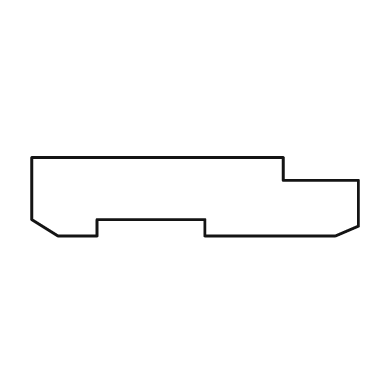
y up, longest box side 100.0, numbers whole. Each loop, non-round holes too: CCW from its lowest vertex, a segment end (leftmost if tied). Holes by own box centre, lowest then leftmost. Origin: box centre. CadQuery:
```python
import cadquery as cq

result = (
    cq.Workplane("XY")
    .moveTo(-42.0, -12.0)
    .lineTo(-30.0, -12.0)
    .lineTo(-30.0, -7.0)
    .lineTo(3.0, -7.0)
    .lineTo(3.0, -12.0)
    .lineTo(43.0, -12.0)
    .lineTo(50.0, -9.0)
    .lineTo(50.0, 5.0)
    .lineTo(27.0, 5.0)
    .lineTo(27.0, 12.0)
    .lineTo(-50.0, 12.0)
    .lineTo(-50.0, -7.0)
    .close()
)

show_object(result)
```